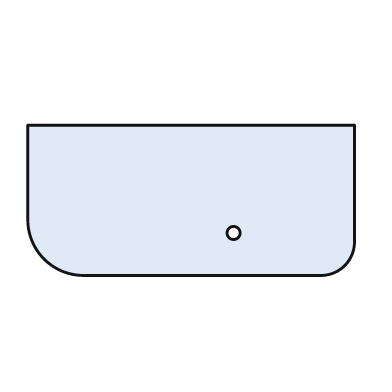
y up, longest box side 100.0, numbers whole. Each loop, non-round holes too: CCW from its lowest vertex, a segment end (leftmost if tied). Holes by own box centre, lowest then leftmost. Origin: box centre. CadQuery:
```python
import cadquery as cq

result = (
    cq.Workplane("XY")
    .moveTo(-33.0, -23.0)
    .lineTo(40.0, -23.0)
    .threePointArc((47.0, -20.0), (50.0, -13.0))
    .lineTo(50.0, 23.0)
    .lineTo(-50.0, 23.0)
    .lineTo(-50.0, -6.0)
    .threePointArc((-45.0, -18.0), (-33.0, -23.0))
    .close()
    .moveTo(13.0, -10.0)
    .circle(2.0)
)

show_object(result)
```